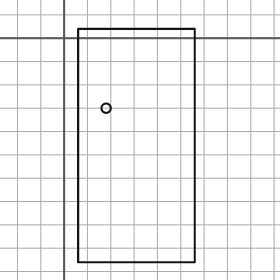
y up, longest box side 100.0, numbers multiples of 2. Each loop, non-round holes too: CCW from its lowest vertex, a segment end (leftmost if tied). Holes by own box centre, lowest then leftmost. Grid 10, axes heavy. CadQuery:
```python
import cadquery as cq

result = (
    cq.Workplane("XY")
    .moveTo(6.0, -96.0)
    .lineTo(56.0, -96.0)
    .lineTo(56.0, 4.0)
    .lineTo(6.0, 4.0)
    .close()
    .moveTo(18.0, -30.0)
    .circle(2.0)
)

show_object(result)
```